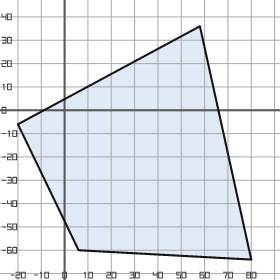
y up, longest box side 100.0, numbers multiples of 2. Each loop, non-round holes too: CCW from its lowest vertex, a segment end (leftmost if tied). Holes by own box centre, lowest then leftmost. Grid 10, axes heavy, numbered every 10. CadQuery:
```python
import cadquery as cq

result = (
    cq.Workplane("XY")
    .moveTo(80.0, -64.0)
    .lineTo(58.0, 36.0)
    .lineTo(-20.0, -6.0)
    .lineTo(6.0, -60.0)
    .close()
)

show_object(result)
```